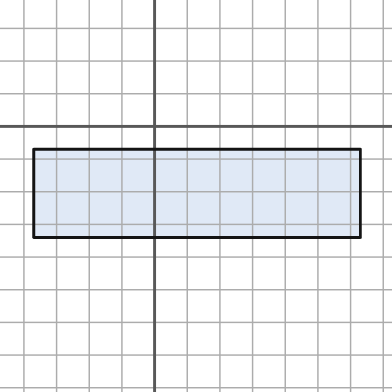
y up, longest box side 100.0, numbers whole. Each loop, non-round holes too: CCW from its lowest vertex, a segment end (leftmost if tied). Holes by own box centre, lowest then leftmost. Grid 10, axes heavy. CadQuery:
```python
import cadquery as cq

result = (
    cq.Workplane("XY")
    .moveTo(-37.0, -34.0)
    .lineTo(63.0, -34.0)
    .lineTo(63.0, -7.0)
    .lineTo(-37.0, -7.0)
    .close()
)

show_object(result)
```